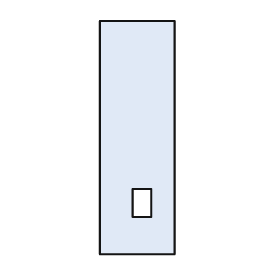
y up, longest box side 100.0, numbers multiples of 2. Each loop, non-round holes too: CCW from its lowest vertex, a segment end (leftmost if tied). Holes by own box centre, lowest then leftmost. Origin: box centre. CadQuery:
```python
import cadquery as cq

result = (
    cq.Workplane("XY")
    .moveTo(-16.0, -50.0)
    .lineTo(16.0, -50.0)
    .lineTo(16.0, 50.0)
    .lineTo(-16.0, 50.0)
    .close()
    .moveTo(-2.0, -34.0)
    .lineTo(6.0, -34.0)
    .lineTo(6.0, -22.0)
    .lineTo(-2.0, -22.0)
    .close()
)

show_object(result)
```